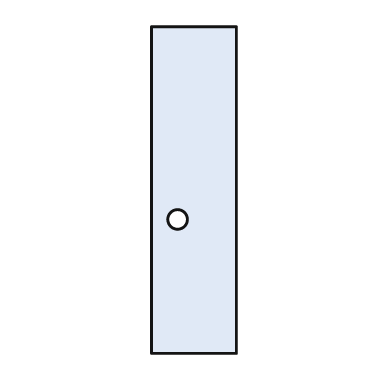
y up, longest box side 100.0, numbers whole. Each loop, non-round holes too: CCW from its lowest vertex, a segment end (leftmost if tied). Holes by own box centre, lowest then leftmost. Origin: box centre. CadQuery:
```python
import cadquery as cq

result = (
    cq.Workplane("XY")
    .moveTo(-13.0, -50.0)
    .lineTo(13.0, -50.0)
    .lineTo(13.0, 50.0)
    .lineTo(-13.0, 50.0)
    .close()
    .moveTo(-5.0, -9.0)
    .circle(3.0)
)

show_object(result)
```